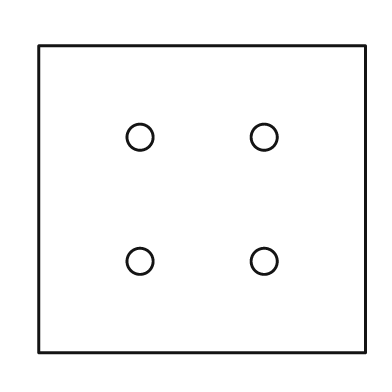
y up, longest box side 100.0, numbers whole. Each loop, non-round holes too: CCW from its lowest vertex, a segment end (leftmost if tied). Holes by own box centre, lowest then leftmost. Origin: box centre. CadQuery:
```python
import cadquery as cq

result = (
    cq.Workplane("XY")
    .moveTo(-50.0, -47.0)
    .lineTo(50.0, -47.0)
    .lineTo(50.0, 47.0)
    .lineTo(-50.0, 47.0)
    .close()
    .moveTo(-19.0, -19.0)
    .circle(4.0)
    .moveTo(19.0, -19.0)
    .circle(4.0)
    .moveTo(-19.0, 19.0)
    .circle(4.0)
    .moveTo(19.0, 19.0)
    .circle(4.0)
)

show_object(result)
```